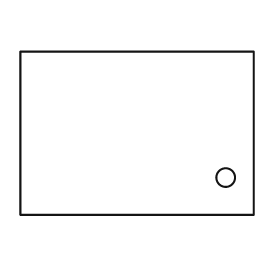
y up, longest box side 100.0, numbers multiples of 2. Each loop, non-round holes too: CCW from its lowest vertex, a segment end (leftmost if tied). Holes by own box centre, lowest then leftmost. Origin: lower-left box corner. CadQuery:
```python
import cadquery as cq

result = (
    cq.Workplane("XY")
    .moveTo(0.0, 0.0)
    .lineTo(100.0, 0.0)
    .lineTo(100.0, 70.0)
    .lineTo(0.0, 70.0)
    .close()
    .moveTo(88.0, 16.0)
    .circle(4.0)
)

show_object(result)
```